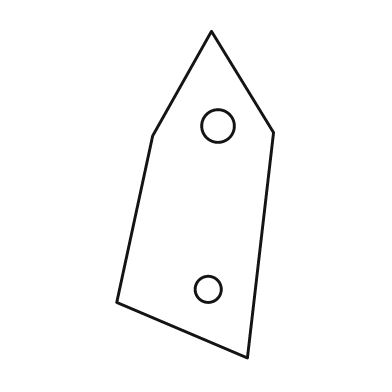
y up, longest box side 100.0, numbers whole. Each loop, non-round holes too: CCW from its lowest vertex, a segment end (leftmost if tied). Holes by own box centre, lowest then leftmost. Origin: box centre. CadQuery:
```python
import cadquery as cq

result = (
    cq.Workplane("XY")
    .moveTo(16.0, -50.0)
    .lineTo(24.0, 19.0)
    .lineTo(5.0, 50.0)
    .lineTo(-13.0, 18.0)
    .lineTo(-24.0, -33.0)
    .close()
    .moveTo(4.0, -29.0)
    .circle(4.0)
    .moveTo(7.0, 21.0)
    .circle(5.0)
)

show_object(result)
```